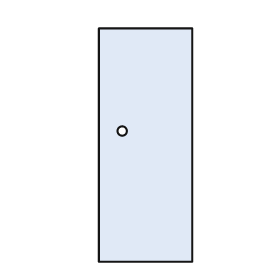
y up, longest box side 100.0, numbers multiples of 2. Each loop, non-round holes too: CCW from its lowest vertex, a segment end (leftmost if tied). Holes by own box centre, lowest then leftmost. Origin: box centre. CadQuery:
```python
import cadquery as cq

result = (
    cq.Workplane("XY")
    .moveTo(-20.0, -50.0)
    .lineTo(20.0, -50.0)
    .lineTo(20.0, 50.0)
    .lineTo(-20.0, 50.0)
    .close()
    .moveTo(-10.0, 6.0)
    .circle(2.0)
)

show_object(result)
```